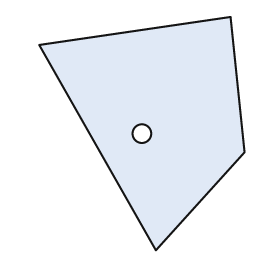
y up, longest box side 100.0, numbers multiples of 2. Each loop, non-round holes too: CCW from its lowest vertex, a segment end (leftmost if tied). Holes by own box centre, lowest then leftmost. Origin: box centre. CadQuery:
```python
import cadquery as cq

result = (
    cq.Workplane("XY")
    .moveTo(6.0, -50.0)
    .lineTo(44.0, -8.0)
    .lineTo(38.0, 50.0)
    .lineTo(-44.0, 38.0)
    .close()
    .moveTo(0.0, 0.0)
    .circle(4.0)
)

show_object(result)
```